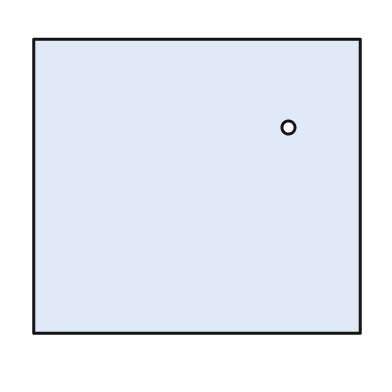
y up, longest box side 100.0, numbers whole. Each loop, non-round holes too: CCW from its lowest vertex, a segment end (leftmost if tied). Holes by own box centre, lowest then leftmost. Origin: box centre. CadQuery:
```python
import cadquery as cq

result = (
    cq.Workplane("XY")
    .moveTo(-50.0, -45.0)
    .lineTo(50.0, -45.0)
    .lineTo(50.0, 45.0)
    .lineTo(-50.0, 45.0)
    .close()
    .moveTo(28.0, 18.0)
    .circle(2.0)
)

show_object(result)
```